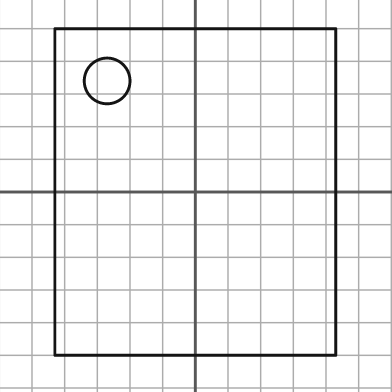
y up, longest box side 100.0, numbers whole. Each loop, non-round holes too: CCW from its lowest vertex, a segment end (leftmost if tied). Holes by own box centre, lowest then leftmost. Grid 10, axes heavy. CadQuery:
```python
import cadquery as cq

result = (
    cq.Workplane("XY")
    .moveTo(-43.0, -50.0)
    .lineTo(43.0, -50.0)
    .lineTo(43.0, 50.0)
    .lineTo(-43.0, 50.0)
    .close()
    .moveTo(-27.0, 34.0)
    .circle(7.0)
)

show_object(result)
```